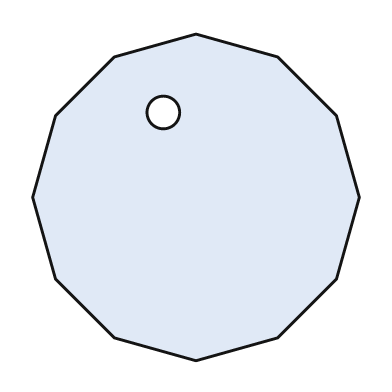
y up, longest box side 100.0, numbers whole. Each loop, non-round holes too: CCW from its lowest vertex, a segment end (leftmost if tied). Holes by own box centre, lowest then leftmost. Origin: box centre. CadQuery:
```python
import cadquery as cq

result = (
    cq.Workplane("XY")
    .moveTo(0.0, -50.0)
    .lineTo(25.0, -43.0)
    .lineTo(43.0, -25.0)
    .lineTo(50.0, 0.0)
    .lineTo(43.0, 25.0)
    .lineTo(25.0, 43.0)
    .lineTo(0.0, 50.0)
    .lineTo(-25.0, 43.0)
    .lineTo(-43.0, 25.0)
    .lineTo(-50.0, 0.0)
    .lineTo(-43.0, -25.0)
    .lineTo(-25.0, -43.0)
    .close()
    .moveTo(-10.0, 26.0)
    .circle(5.0)
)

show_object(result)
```